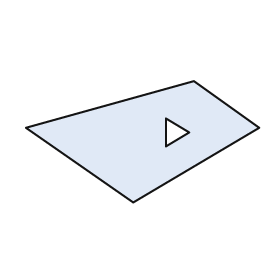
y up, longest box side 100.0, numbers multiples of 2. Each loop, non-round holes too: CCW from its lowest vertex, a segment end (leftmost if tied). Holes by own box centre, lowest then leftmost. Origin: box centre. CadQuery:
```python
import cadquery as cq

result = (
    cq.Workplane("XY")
    .moveTo(-4.0, -26.0)
    .lineTo(50.0, 6.0)
    .lineTo(22.0, 26.0)
    .lineTo(-50.0, 6.0)
    .close()
    .moveTo(10.0, -2.0)
    .lineTo(20.0, 4.0)
    .lineTo(10.0, 10.0)
    .close()
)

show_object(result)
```